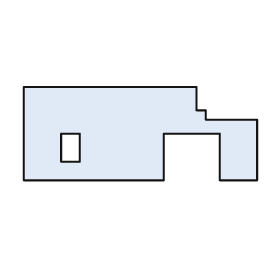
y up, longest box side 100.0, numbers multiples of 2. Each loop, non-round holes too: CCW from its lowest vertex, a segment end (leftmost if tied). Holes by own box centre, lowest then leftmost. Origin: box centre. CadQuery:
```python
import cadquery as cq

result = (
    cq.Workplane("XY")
    .moveTo(-50.0, -20.0)
    .lineTo(10.0, -20.0)
    .lineTo(10.0, 0.0)
    .lineTo(34.0, 0.0)
    .lineTo(34.0, -20.0)
    .lineTo(50.0, -20.0)
    .lineTo(50.0, 6.0)
    .lineTo(28.0, 6.0)
    .lineTo(28.0, 10.0)
    .lineTo(24.0, 10.0)
    .lineTo(24.0, 20.0)
    .lineTo(-50.0, 20.0)
    .close()
    .moveTo(-34.0, -12.0)
    .lineTo(-26.0, -12.0)
    .lineTo(-26.0, 0.0)
    .lineTo(-34.0, 0.0)
    .close()
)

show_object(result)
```